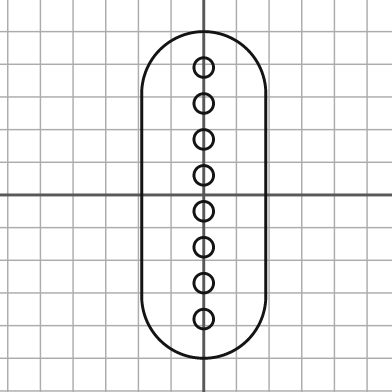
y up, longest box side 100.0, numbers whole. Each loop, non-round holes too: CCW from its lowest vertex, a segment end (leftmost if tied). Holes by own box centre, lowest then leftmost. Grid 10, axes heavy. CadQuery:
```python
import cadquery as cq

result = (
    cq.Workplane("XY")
    .moveTo(-19.0, -31.0)
    .threePointArc((0.0, -50.0), (19.0, -31.0))
    .lineTo(19.0, 31.0)
    .threePointArc((0.0, 50.0), (-19.0, 31.0))
    .close()
    .moveTo(0.0, -38.0)
    .circle(3.0)
    .moveTo(0.0, -27.0)
    .circle(3.0)
    .moveTo(0.0, -16.0)
    .circle(3.0)
    .moveTo(0.0, -5.0)
    .circle(3.0)
    .moveTo(0.0, 6.0)
    .circle(3.0)
    .moveTo(0.0, 17.0)
    .circle(3.0)
    .moveTo(0.0, 28.0)
    .circle(3.0)
    .moveTo(0.0, 39.0)
    .circle(3.0)
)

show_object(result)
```